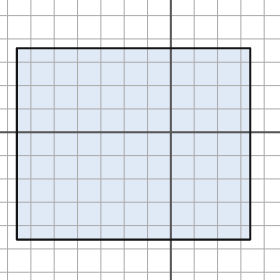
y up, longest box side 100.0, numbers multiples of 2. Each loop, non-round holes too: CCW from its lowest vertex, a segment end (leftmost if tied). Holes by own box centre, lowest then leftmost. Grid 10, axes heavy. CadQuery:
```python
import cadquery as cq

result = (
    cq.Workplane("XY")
    .moveTo(-66.0, -46.0)
    .lineTo(34.0, -46.0)
    .lineTo(34.0, 36.0)
    .lineTo(-66.0, 36.0)
    .close()
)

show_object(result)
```